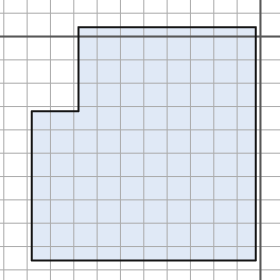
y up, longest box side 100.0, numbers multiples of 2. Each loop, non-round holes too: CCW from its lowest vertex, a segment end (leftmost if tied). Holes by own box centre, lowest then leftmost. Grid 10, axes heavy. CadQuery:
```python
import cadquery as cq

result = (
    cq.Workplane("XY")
    .moveTo(-98.0, -96.0)
    .lineTo(-2.0, -96.0)
    .lineTo(-2.0, 4.0)
    .lineTo(-78.0, 4.0)
    .lineTo(-78.0, -32.0)
    .lineTo(-98.0, -32.0)
    .close()
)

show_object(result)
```